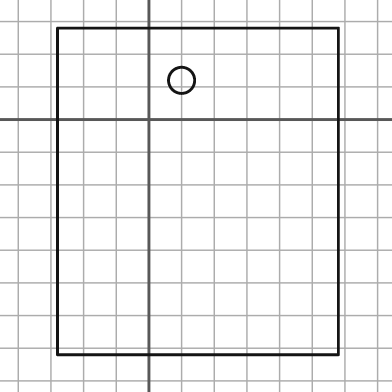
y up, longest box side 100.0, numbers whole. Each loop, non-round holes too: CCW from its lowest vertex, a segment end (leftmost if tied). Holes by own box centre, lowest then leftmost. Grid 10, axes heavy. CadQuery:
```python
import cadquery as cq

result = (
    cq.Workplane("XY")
    .moveTo(-28.0, -72.0)
    .lineTo(58.0, -72.0)
    .lineTo(58.0, 28.0)
    .lineTo(-28.0, 28.0)
    .close()
    .moveTo(10.0, 12.0)
    .circle(4.0)
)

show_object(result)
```